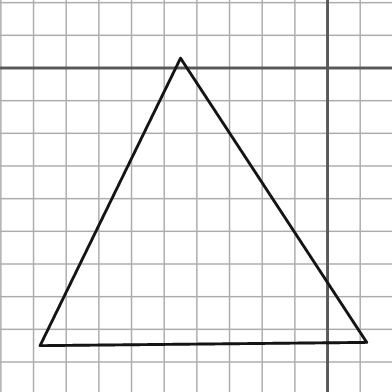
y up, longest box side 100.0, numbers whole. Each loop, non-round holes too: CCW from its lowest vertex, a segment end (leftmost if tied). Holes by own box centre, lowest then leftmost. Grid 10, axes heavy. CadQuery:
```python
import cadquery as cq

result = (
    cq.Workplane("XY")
    .moveTo(-88.0, -85.0)
    .lineTo(12.0, -84.0)
    .lineTo(-45.0, 3.0)
    .close()
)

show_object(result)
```